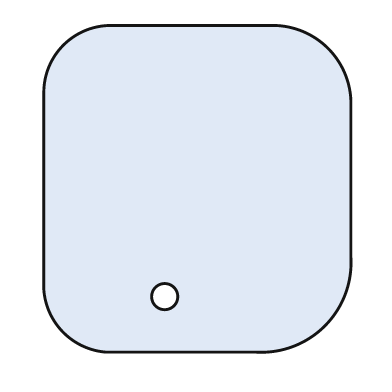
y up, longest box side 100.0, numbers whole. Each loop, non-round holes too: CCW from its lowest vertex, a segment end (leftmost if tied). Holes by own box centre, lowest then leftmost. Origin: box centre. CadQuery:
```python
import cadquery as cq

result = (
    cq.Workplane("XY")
    .moveTo(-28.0, -50.0)
    .lineTo(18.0, -50.0)
    .threePointArc((39.0, -42.0), (47.0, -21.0))
    .lineTo(47.0, 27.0)
    .threePointArc((40.0, 43.0), (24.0, 50.0))
    .lineTo(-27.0, 50.0)
    .threePointArc((-41.0, 44.0), (-47.0, 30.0))
    .lineTo(-47.0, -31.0)
    .threePointArc((-41.0, -44.0), (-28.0, -50.0))
    .close()
    .moveTo(-10.0, -33.0)
    .circle(4.0)
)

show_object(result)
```